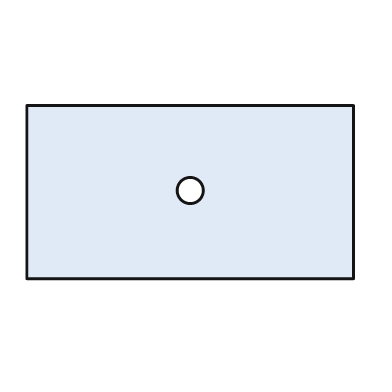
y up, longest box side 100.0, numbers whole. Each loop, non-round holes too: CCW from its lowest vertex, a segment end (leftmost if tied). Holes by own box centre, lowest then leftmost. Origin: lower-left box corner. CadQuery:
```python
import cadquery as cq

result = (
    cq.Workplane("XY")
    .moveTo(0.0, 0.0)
    .lineTo(100.0, 0.0)
    .lineTo(100.0, 53.0)
    .lineTo(0.0, 53.0)
    .close()
    .moveTo(50.0, 27.0)
    .circle(4.0)
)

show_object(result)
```